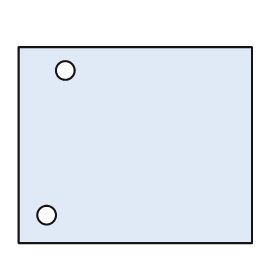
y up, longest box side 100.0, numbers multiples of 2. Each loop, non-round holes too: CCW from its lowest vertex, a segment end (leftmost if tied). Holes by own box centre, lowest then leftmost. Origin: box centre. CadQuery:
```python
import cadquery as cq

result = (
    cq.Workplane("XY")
    .moveTo(-50.0, -42.0)
    .lineTo(50.0, -42.0)
    .lineTo(50.0, 42.0)
    .lineTo(-50.0, 42.0)
    .close()
    .moveTo(-38.0, -30.0)
    .circle(4.0)
    .moveTo(-30.0, 32.0)
    .circle(4.0)
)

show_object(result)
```